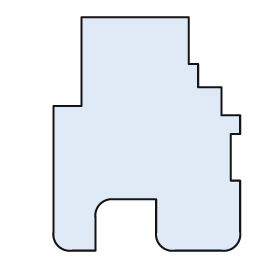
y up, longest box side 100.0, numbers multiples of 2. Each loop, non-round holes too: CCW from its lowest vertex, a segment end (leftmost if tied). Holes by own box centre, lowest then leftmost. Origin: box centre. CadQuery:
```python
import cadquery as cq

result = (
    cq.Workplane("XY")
    .moveTo(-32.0, -50.0)
    .lineTo(-22.0, -50.0)
    .lineTo(-22.0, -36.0)
    .threePointArc((-20.0, -30.0), (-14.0, -28.0))
    .lineTo(4.0, -28.0)
    .lineTo(4.0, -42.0)
    .threePointArc((6.0, -48.0), (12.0, -50.0))
    .lineTo(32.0, -50.0)
    .threePointArc((38.0, -48.0), (40.0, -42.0))
    .lineTo(40.0, -20.0)
    .lineTo(36.0, -20.0)
    .lineTo(36.0, 0.0)
    .lineTo(40.0, 0.0)
    .lineTo(40.0, 8.0)
    .lineTo(32.0, 8.0)
    .lineTo(32.0, 20.0)
    .lineTo(22.0, 20.0)
    .lineTo(22.0, 30.0)
    .lineTo(18.0, 30.0)
    .lineTo(18.0, 50.0)
    .lineTo(-28.0, 50.0)
    .lineTo(-28.0, 12.0)
    .lineTo(-40.0, 12.0)
    .lineTo(-40.0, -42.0)
    .threePointArc((-38.0, -48.0), (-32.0, -50.0))
    .close()
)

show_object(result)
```